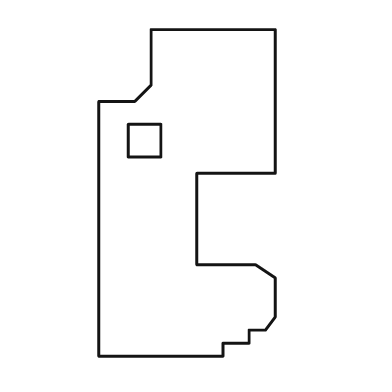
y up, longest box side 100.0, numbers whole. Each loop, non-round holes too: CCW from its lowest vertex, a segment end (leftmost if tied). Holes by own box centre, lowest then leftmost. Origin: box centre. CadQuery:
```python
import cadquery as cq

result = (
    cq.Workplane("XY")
    .moveTo(-27.0, -50.0)
    .lineTo(11.0, -50.0)
    .lineTo(11.0, -46.0)
    .lineTo(19.0, -46.0)
    .lineTo(19.0, -42.0)
    .lineTo(24.0, -42.0)
    .lineTo(27.0, -38.0)
    .lineTo(27.0, -26.0)
    .lineTo(21.0, -22.0)
    .lineTo(3.0, -22.0)
    .lineTo(3.0, 6.0)
    .lineTo(27.0, 6.0)
    .lineTo(27.0, 50.0)
    .lineTo(-11.0, 50.0)
    .lineTo(-11.0, 33.0)
    .lineTo(-16.0, 28.0)
    .lineTo(-27.0, 28.0)
    .close()
    .moveTo(-18.0, 11.0)
    .lineTo(-8.0, 11.0)
    .lineTo(-8.0, 21.0)
    .lineTo(-18.0, 21.0)
    .close()
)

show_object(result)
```